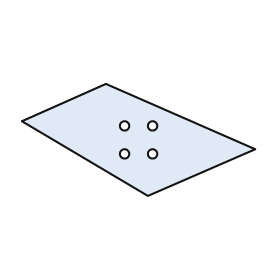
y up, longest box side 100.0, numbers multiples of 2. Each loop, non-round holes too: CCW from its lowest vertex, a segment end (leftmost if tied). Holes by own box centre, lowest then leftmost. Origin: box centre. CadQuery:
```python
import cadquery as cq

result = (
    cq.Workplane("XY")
    .moveTo(4.0, -24.0)
    .lineTo(50.0, -4.0)
    .lineTo(-14.0, 24.0)
    .lineTo(-50.0, 8.0)
    .close()
    .moveTo(-6.0, -6.0)
    .circle(2.0)
    .moveTo(6.0, -6.0)
    .circle(2.0)
    .moveTo(-6.0, 6.0)
    .circle(2.0)
    .moveTo(6.0, 6.0)
    .circle(2.0)
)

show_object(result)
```